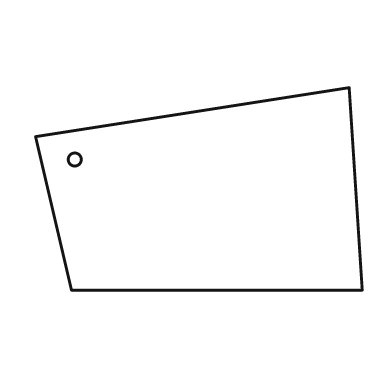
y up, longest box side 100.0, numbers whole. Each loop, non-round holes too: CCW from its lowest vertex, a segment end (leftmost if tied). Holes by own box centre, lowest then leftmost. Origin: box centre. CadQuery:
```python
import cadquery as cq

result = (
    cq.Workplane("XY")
    .moveTo(-39.0, -31.0)
    .lineTo(50.0, -31.0)
    .lineTo(46.0, 31.0)
    .lineTo(-50.0, 16.0)
    .close()
    .moveTo(-38.0, 9.0)
    .circle(2.0)
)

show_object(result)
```